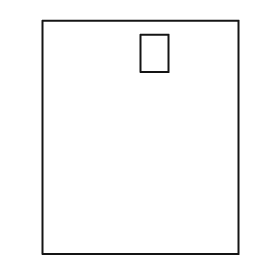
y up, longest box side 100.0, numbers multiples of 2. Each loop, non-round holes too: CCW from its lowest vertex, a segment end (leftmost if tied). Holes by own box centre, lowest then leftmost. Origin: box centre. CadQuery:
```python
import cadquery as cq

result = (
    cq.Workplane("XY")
    .moveTo(-42.0, -50.0)
    .lineTo(42.0, -50.0)
    .lineTo(42.0, 50.0)
    .lineTo(-42.0, 50.0)
    .close()
    .moveTo(0.0, 28.0)
    .lineTo(12.0, 28.0)
    .lineTo(12.0, 44.0)
    .lineTo(0.0, 44.0)
    .close()
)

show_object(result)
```